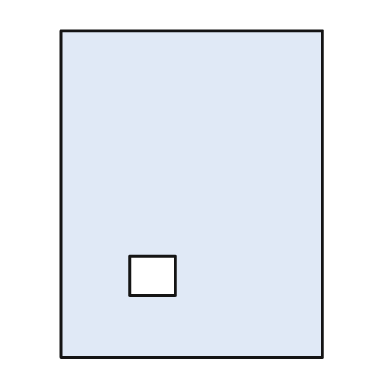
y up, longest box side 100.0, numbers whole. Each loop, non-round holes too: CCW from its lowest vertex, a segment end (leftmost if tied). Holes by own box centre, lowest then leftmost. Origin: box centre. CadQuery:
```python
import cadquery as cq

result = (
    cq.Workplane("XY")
    .moveTo(-40.0, -50.0)
    .lineTo(40.0, -50.0)
    .lineTo(40.0, 50.0)
    .lineTo(-40.0, 50.0)
    .close()
    .moveTo(-19.0, -31.0)
    .lineTo(-5.0, -31.0)
    .lineTo(-5.0, -19.0)
    .lineTo(-19.0, -19.0)
    .close()
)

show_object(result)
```